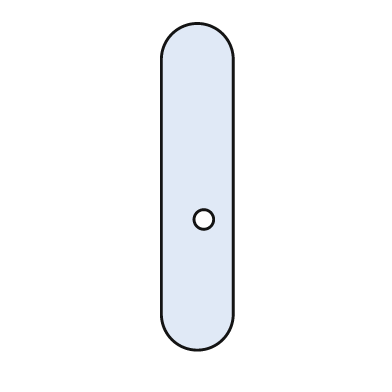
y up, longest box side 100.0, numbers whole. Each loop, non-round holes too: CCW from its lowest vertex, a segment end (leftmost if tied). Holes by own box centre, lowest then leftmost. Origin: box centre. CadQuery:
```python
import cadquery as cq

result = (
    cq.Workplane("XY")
    .moveTo(-11.0, -39.0)
    .threePointArc((0.0, -50.0), (11.0, -39.0))
    .lineTo(11.0, 39.0)
    .threePointArc((0.0, 50.0), (-11.0, 39.0))
    .close()
    .moveTo(2.0, -10.0)
    .circle(3.0)
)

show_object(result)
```